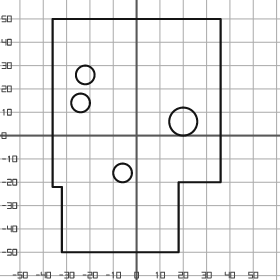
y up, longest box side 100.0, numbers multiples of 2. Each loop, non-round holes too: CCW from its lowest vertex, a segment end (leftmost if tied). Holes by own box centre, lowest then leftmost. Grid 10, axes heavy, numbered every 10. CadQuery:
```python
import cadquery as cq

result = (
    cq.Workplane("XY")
    .moveTo(-32.0, -50.0)
    .lineTo(18.0, -50.0)
    .lineTo(18.0, -20.0)
    .lineTo(36.0, -20.0)
    .lineTo(36.0, 50.0)
    .lineTo(-36.0, 50.0)
    .lineTo(-36.0, -22.0)
    .lineTo(-32.0, -22.0)
    .close()
    .moveTo(-6.0, -16.0)
    .circle(4.0)
    .moveTo(20.0, 6.0)
    .circle(6.0)
    .moveTo(-24.0, 14.0)
    .circle(4.0)
    .moveTo(-22.0, 26.0)
    .circle(4.0)
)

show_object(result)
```